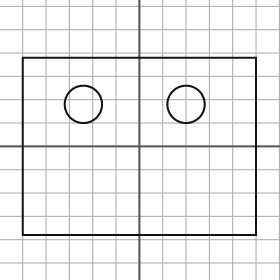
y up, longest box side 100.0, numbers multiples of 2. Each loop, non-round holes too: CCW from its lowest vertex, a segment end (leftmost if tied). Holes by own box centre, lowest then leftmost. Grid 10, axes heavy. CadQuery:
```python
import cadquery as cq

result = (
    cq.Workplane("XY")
    .moveTo(-50.0, -38.0)
    .lineTo(50.0, -38.0)
    .lineTo(50.0, 38.0)
    .lineTo(-50.0, 38.0)
    .close()
    .moveTo(-24.0, 18.0)
    .circle(8.0)
    .moveTo(20.0, 18.0)
    .circle(8.0)
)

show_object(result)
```